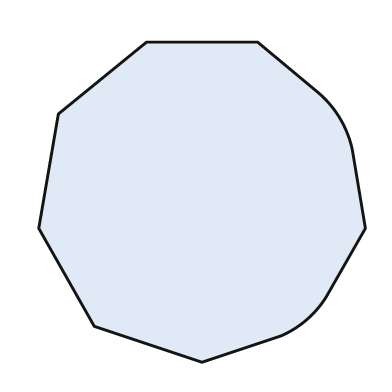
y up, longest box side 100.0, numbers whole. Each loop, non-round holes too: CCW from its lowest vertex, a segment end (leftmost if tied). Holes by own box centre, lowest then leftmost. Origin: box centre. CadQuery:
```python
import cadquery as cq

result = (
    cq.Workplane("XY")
    .moveTo(0.0, -49.0)
    .lineTo(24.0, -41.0)
    .threePointArc((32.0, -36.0), (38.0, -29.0))
    .lineTo(50.0, -8.0)
    .lineTo(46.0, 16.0)
    .threePointArc((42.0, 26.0), (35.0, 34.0))
    .lineTo(17.0, 49.0)
    .lineTo(-17.0, 49.0)
    .lineTo(-44.0, 27.0)
    .lineTo(-50.0, -8.0)
    .lineTo(-33.0, -38.0)
    .close()
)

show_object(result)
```